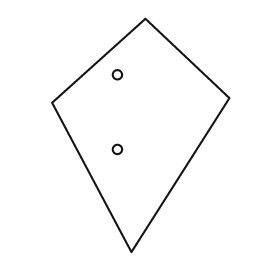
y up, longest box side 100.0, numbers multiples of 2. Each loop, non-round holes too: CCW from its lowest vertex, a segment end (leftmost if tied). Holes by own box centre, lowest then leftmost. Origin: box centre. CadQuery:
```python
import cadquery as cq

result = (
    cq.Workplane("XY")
    .moveTo(-4.0, -50.0)
    .lineTo(38.0, 16.0)
    .lineTo(2.0, 50.0)
    .lineTo(-38.0, 14.0)
    .close()
    .moveTo(-10.0, -6.0)
    .circle(2.0)
    .moveTo(-10.0, 26.0)
    .circle(2.0)
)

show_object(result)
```